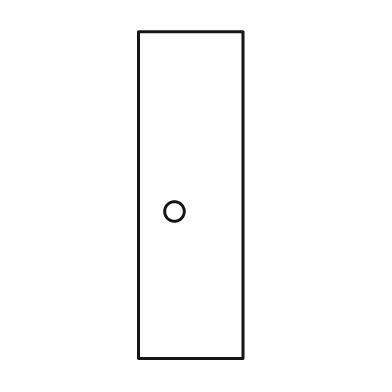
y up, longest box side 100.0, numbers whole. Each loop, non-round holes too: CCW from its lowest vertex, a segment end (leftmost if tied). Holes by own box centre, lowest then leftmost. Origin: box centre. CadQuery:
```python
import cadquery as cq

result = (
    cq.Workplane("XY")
    .moveTo(-16.0, -50.0)
    .lineTo(16.0, -50.0)
    .lineTo(16.0, 50.0)
    .lineTo(-16.0, 50.0)
    .close()
    .moveTo(-5.0, -5.0)
    .circle(3.0)
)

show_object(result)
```